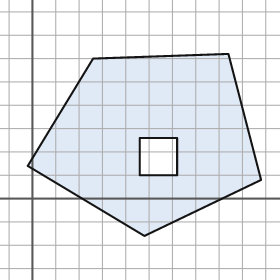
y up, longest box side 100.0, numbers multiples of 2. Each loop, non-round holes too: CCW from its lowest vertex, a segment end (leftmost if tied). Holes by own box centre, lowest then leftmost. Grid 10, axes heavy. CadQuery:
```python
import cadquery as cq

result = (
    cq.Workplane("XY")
    .moveTo(48.0, -16.0)
    .lineTo(98.0, 8.0)
    .lineTo(84.0, 62.0)
    .lineTo(26.0, 60.0)
    .lineTo(-2.0, 14.0)
    .close()
    .moveTo(46.0, 10.0)
    .lineTo(62.0, 10.0)
    .lineTo(62.0, 26.0)
    .lineTo(46.0, 26.0)
    .close()
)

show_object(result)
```